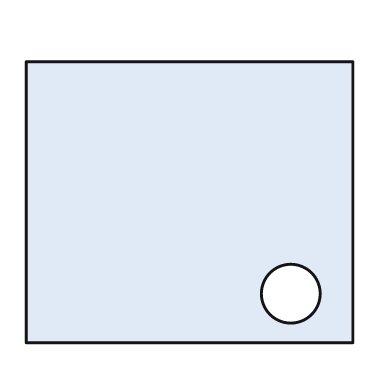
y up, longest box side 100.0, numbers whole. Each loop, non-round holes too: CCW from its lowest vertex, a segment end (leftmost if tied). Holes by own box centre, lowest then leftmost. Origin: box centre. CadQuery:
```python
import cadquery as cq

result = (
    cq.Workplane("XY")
    .moveTo(-50.0, -43.0)
    .lineTo(50.0, -43.0)
    .lineTo(50.0, 43.0)
    .lineTo(-50.0, 43.0)
    .close()
    .moveTo(31.0, -28.0)
    .circle(9.0)
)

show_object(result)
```